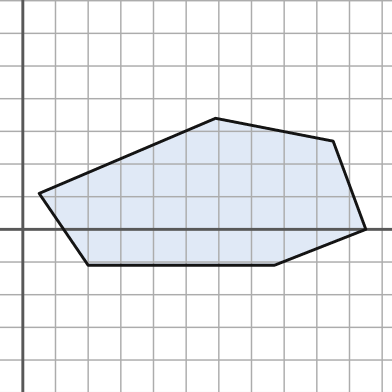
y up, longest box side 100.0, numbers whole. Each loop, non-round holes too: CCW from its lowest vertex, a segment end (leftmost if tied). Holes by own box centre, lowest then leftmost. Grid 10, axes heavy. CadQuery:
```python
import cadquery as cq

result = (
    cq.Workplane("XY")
    .moveTo(20.0, -11.0)
    .lineTo(77.0, -11.0)
    .lineTo(105.0, 0.0)
    .lineTo(95.0, 27.0)
    .lineTo(59.0, 34.0)
    .lineTo(5.0, 11.0)
    .close()
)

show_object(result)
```